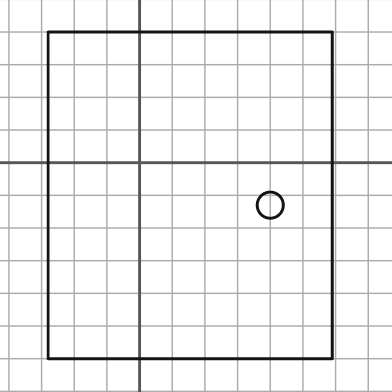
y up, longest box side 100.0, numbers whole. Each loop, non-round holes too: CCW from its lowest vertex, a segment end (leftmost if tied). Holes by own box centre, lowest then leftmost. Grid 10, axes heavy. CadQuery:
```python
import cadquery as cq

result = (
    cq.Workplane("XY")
    .moveTo(-28.0, -60.0)
    .lineTo(59.0, -60.0)
    .lineTo(59.0, 40.0)
    .lineTo(-28.0, 40.0)
    .close()
    .moveTo(40.0, -13.0)
    .circle(4.0)
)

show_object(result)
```